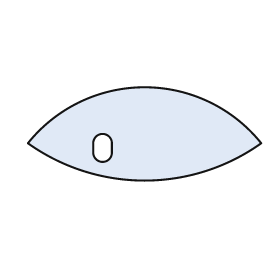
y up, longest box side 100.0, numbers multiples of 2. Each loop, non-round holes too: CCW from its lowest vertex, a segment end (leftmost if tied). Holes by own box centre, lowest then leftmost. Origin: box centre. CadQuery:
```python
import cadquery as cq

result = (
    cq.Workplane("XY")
    .moveTo(-50.0, -4.0)
    .threePointArc((0.0, -20.0), (50.0, -4.0))
    .threePointArc((0.0, 20.0), (-50.0, -4.0))
    .close()
    .moveTo(-22.0, -8.0)
    .threePointArc((-18.0, -12.0), (-14.0, -8.0))
    .lineTo(-14.0, -4.0)
    .threePointArc((-18.0, 0.0), (-22.0, -4.0))
    .close()
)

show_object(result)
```